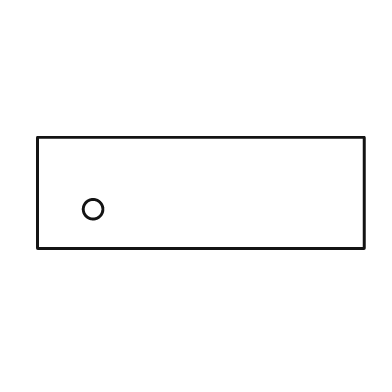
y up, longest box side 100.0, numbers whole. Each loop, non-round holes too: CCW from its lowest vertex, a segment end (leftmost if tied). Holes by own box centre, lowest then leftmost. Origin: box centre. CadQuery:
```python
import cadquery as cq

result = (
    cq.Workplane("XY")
    .moveTo(-50.0, -17.0)
    .lineTo(50.0, -17.0)
    .lineTo(50.0, 17.0)
    .lineTo(-50.0, 17.0)
    .close()
    .moveTo(-33.0, -5.0)
    .circle(3.0)
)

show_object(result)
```